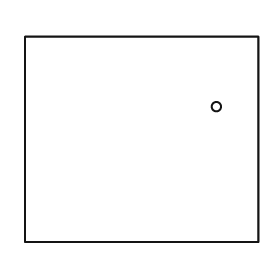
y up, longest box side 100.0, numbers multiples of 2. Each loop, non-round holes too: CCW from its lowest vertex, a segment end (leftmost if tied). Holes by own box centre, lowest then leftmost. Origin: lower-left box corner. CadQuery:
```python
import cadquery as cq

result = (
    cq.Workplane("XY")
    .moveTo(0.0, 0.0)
    .lineTo(100.0, 0.0)
    .lineTo(100.0, 88.0)
    .lineTo(0.0, 88.0)
    .close()
    .moveTo(82.0, 58.0)
    .circle(2.0)
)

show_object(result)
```